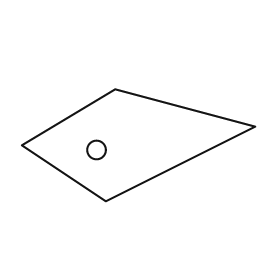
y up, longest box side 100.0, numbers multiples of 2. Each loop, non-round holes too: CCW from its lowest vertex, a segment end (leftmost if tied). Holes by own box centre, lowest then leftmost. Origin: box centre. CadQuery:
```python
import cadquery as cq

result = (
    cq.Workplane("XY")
    .moveTo(-14.0, -24.0)
    .lineTo(50.0, 8.0)
    .lineTo(-10.0, 24.0)
    .lineTo(-50.0, 0.0)
    .close()
    .moveTo(-18.0, -2.0)
    .circle(4.0)
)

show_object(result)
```